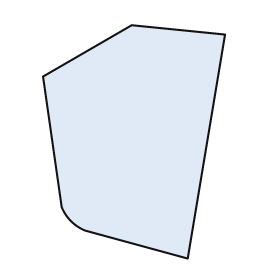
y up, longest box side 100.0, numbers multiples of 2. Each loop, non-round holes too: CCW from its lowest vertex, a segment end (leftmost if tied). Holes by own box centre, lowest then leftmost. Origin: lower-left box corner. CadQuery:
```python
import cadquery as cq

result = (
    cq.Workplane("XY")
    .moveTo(62.0, 0.0)
    .lineTo(78.0, 96.0)
    .lineTo(38.0, 100.0)
    .lineTo(0.0, 78.0)
    .lineTo(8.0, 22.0)
    .threePointArc((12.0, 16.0), (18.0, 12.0))
    .close()
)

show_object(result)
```